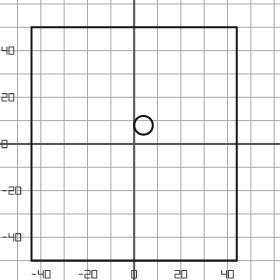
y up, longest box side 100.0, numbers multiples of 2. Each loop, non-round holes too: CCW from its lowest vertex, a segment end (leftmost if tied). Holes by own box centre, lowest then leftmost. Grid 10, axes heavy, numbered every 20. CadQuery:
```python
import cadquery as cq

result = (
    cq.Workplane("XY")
    .moveTo(-44.0, -50.0)
    .lineTo(44.0, -50.0)
    .lineTo(44.0, 50.0)
    .lineTo(-44.0, 50.0)
    .close()
    .moveTo(4.0, 8.0)
    .circle(4.0)
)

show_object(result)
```